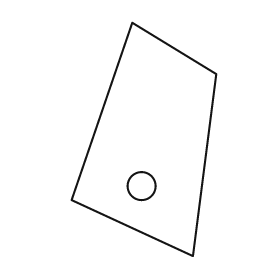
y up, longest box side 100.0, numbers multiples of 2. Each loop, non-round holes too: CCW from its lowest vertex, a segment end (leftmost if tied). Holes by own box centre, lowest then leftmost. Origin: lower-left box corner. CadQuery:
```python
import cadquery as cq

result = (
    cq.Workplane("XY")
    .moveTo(52.0, 0.0)
    .lineTo(62.0, 78.0)
    .lineTo(26.0, 100.0)
    .lineTo(0.0, 24.0)
    .close()
    .moveTo(30.0, 30.0)
    .circle(6.0)
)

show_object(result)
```